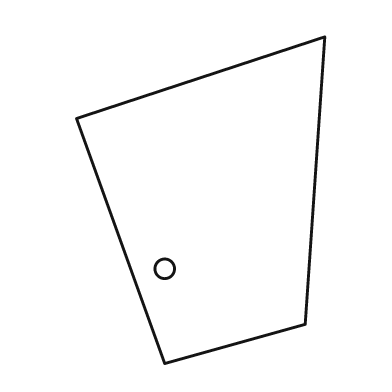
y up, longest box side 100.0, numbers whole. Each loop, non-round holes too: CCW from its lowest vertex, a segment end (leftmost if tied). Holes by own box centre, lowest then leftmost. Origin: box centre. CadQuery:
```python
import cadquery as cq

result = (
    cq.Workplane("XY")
    .moveTo(-11.0, -50.0)
    .lineTo(32.0, -38.0)
    .lineTo(38.0, 50.0)
    .lineTo(-38.0, 25.0)
    .close()
    .moveTo(-11.0, -21.0)
    .circle(3.0)
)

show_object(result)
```